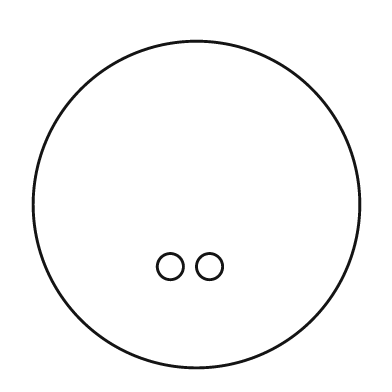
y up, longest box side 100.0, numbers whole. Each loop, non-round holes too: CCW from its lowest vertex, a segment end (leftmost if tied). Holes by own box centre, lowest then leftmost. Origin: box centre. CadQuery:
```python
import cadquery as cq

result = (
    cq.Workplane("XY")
    .moveTo(0.0, 0.0)
    .circle(50.0)
    .moveTo(-8.0, -19.0)
    .circle(4.0)
    .moveTo(4.0, -19.0)
    .circle(4.0)
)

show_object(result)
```